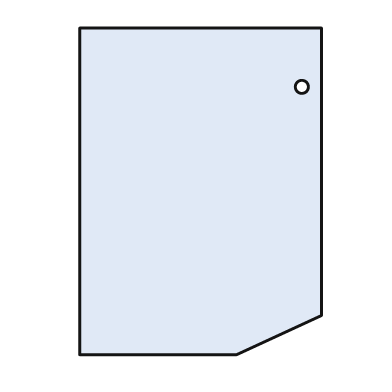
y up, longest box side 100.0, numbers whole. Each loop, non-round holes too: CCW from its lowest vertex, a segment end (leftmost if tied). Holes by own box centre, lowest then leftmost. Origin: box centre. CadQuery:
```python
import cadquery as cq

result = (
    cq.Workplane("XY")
    .moveTo(-37.0, -50.0)
    .lineTo(11.0, -50.0)
    .lineTo(37.0, -38.0)
    .lineTo(37.0, 50.0)
    .lineTo(-37.0, 50.0)
    .close()
    .moveTo(31.0, 32.0)
    .circle(2.0)
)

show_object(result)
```